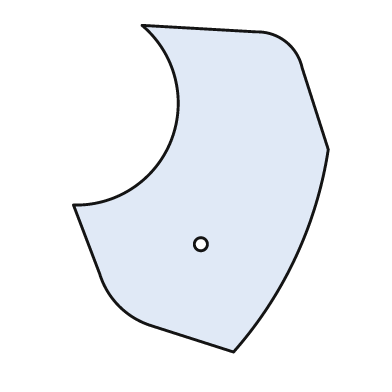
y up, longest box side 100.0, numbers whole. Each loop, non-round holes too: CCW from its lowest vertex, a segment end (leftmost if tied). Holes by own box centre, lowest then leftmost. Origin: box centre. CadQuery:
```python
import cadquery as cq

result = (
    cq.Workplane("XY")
    .moveTo(10.0, -50.0)
    .threePointArc((29.0, -21.0), (39.0, 12.0))
    .lineTo(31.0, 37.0)
    .threePointArc((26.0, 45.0), (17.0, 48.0))
    .lineTo(-18.0, 50.0)
    .threePointArc((-9.0, 15.0), (-39.0, -5.0))
    .lineTo(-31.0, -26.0)
    .threePointArc((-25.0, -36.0), (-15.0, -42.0))
    .close()
    .moveTo(0.0, -17.0)
    .circle(2.0)
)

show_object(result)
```